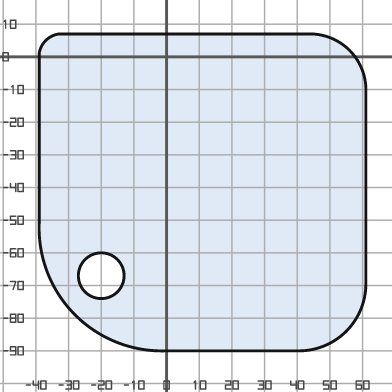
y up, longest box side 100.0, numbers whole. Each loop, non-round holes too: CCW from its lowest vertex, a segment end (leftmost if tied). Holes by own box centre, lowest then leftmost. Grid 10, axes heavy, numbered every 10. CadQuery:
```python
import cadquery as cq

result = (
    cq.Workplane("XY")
    .moveTo(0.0, -90.0)
    .lineTo(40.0, -90.0)
    .threePointArc((55.0, -84.0), (61.0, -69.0))
    .lineTo(61.0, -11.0)
    .threePointArc((56.0, 2.0), (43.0, 7.0))
    .lineTo(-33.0, 7.0)
    .threePointArc((-37.0, 5.0), (-39.0, 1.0))
    .lineTo(-39.0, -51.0)
    .threePointArc((-28.0, -79.0), (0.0, -90.0))
    .close()
    .moveTo(-20.0, -67.0)
    .circle(7.0)
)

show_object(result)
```